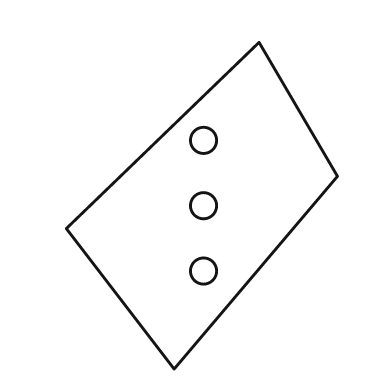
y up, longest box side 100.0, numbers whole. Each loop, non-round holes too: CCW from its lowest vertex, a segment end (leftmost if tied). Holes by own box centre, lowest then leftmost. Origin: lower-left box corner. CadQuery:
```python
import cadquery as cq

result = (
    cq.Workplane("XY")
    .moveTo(33.0, 0.0)
    .lineTo(83.0, 59.0)
    .lineTo(59.0, 100.0)
    .lineTo(0.0, 43.0)
    .close()
    .moveTo(42.0, 30.0)
    .circle(4.0)
    .moveTo(42.0, 50.0)
    .circle(4.0)
    .moveTo(42.0, 70.0)
    .circle(4.0)
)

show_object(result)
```